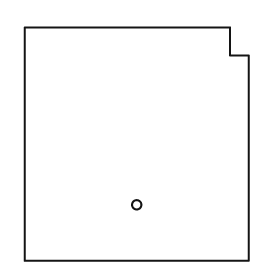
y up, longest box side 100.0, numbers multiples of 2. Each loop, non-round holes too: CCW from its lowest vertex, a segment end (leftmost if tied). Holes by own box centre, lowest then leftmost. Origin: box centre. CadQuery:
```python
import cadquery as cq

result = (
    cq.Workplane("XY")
    .moveTo(-48.0, -50.0)
    .lineTo(48.0, -50.0)
    .lineTo(48.0, 38.0)
    .lineTo(40.0, 38.0)
    .lineTo(40.0, 50.0)
    .lineTo(-48.0, 50.0)
    .close()
    .moveTo(0.0, -26.0)
    .circle(2.0)
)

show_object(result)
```